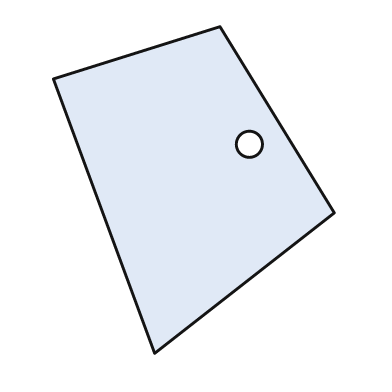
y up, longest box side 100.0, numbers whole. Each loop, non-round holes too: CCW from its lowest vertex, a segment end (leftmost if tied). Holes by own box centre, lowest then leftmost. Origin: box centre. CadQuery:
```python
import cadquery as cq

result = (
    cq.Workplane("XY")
    .moveTo(-12.0, -50.0)
    .lineTo(43.0, -7.0)
    .lineTo(8.0, 50.0)
    .lineTo(-43.0, 34.0)
    .close()
    .moveTo(17.0, 14.0)
    .circle(4.0)
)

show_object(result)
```